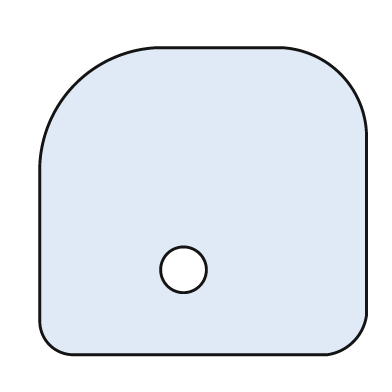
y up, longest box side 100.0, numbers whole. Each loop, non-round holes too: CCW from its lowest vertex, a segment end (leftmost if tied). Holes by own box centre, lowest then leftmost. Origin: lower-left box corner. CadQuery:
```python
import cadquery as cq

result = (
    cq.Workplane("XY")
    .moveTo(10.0, 0.0)
    .lineTo(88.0, 0.0)
    .threePointArc((96.0, 4.0), (100.0, 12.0))
    .lineTo(100.0, 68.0)
    .threePointArc((92.0, 86.0), (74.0, 94.0))
    .lineTo(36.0, 94.0)
    .threePointArc((11.0, 83.0), (0.0, 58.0))
    .lineTo(0.0, 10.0)
    .threePointArc((3.0, 3.0), (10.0, 0.0))
    .close()
    .moveTo(44.0, 26.0)
    .circle(7.0)
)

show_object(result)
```